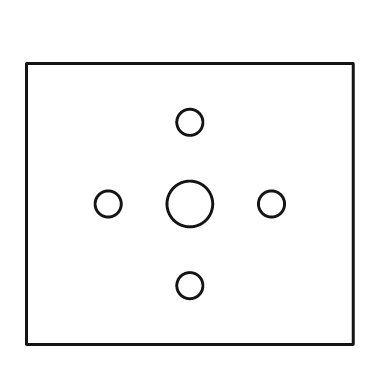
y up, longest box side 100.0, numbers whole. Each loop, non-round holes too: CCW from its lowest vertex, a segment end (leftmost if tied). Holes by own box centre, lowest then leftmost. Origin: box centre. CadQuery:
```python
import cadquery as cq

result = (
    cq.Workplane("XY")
    .moveTo(-50.0, -43.0)
    .lineTo(50.0, -43.0)
    .lineTo(50.0, 43.0)
    .lineTo(-50.0, 43.0)
    .close()
    .moveTo(0.0, -25.0)
    .circle(4.0)
    .moveTo(-25.0, 0.0)
    .circle(4.0)
    .moveTo(0.0, 0.0)
    .circle(7.0)
    .moveTo(25.0, 0.0)
    .circle(4.0)
    .moveTo(0.0, 25.0)
    .circle(4.0)
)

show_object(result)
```